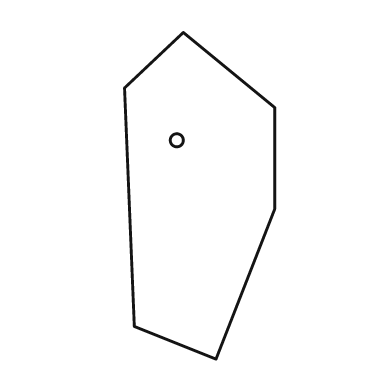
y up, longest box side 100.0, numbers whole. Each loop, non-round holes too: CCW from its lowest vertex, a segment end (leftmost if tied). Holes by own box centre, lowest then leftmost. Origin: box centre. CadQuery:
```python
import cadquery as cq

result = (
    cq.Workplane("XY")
    .moveTo(5.0, -50.0)
    .lineTo(23.0, -4.0)
    .lineTo(23.0, 27.0)
    .lineTo(-5.0, 50.0)
    .lineTo(-23.0, 33.0)
    .lineTo(-20.0, -40.0)
    .close()
    .moveTo(-7.0, 17.0)
    .circle(2.0)
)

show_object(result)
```